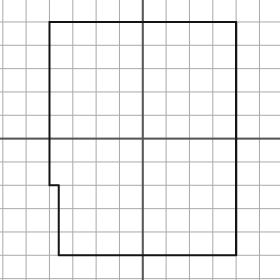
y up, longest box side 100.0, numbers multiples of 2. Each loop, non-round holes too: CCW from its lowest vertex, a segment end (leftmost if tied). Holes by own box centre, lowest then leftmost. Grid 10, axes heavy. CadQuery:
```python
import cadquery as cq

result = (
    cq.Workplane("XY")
    .moveTo(-36.0, -50.0)
    .lineTo(40.0, -50.0)
    .lineTo(40.0, 50.0)
    .lineTo(-40.0, 50.0)
    .lineTo(-40.0, -20.0)
    .lineTo(-36.0, -20.0)
    .close()
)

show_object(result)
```